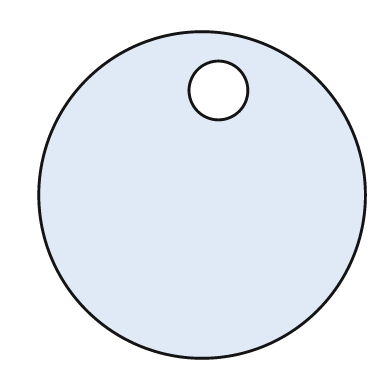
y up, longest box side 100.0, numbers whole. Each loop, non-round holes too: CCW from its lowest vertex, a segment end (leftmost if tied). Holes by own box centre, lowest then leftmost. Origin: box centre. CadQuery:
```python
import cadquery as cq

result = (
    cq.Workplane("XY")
    .moveTo(0.0, 0.0)
    .circle(50.0)
    .moveTo(5.0, 32.0)
    .circle(9.0)
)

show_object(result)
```